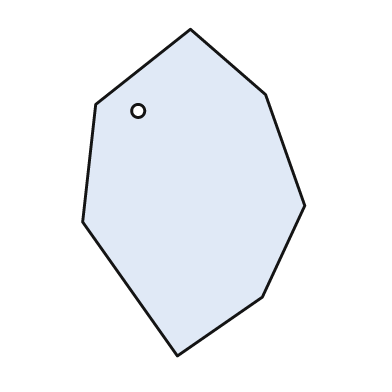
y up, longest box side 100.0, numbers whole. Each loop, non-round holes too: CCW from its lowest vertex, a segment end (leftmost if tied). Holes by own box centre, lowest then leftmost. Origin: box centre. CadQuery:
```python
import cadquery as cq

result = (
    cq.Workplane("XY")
    .moveTo(-5.0, -50.0)
    .lineTo(21.0, -32.0)
    .lineTo(34.0, -4.0)
    .lineTo(22.0, 30.0)
    .lineTo(-1.0, 50.0)
    .lineTo(-30.0, 27.0)
    .lineTo(-34.0, -9.0)
    .close()
    .moveTo(-17.0, 25.0)
    .circle(2.0)
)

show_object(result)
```